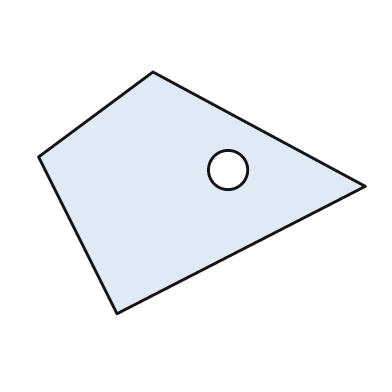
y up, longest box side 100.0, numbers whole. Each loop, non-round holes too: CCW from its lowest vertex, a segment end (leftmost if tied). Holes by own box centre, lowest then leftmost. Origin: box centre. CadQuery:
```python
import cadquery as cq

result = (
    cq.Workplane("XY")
    .moveTo(-26.0, -37.0)
    .lineTo(50.0, 2.0)
    .lineTo(-15.0, 37.0)
    .lineTo(-50.0, 11.0)
    .close()
    .moveTo(8.0, 7.0)
    .circle(6.0)
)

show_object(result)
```